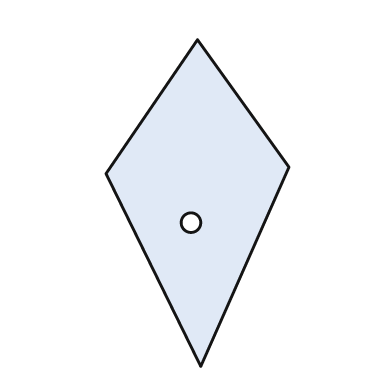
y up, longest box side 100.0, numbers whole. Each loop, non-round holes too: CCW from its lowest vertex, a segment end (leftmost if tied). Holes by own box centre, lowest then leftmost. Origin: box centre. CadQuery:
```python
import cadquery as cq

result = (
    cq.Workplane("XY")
    .moveTo(1.0, -50.0)
    .lineTo(28.0, 11.0)
    .lineTo(0.0, 50.0)
    .lineTo(-28.0, 9.0)
    .close()
    .moveTo(-2.0, -6.0)
    .circle(3.0)
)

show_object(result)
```